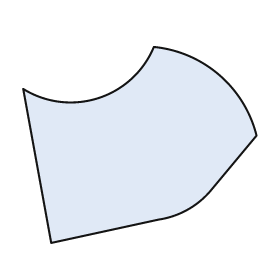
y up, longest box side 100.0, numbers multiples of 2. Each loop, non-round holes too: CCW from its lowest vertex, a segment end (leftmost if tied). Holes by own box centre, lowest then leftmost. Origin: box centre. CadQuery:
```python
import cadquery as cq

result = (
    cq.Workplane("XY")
    .moveTo(-38.0, -42.0)
    .lineTo(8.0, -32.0)
    .threePointArc((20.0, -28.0), (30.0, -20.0))
    .lineTo(50.0, 4.0)
    .threePointArc((34.0, 30.0), (6.0, 42.0))
    .threePointArc((-18.0, 20.0), (-50.0, 24.0))
    .close()
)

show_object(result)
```